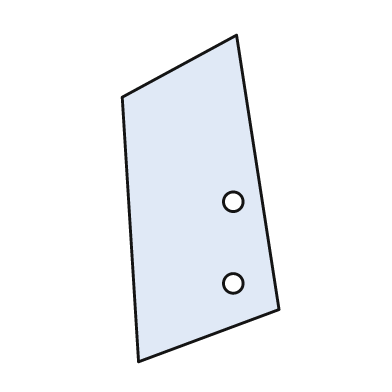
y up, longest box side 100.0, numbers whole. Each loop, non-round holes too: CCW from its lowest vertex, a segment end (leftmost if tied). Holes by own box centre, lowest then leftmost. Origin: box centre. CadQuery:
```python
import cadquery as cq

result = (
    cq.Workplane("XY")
    .moveTo(-19.0, -50.0)
    .lineTo(24.0, -34.0)
    .lineTo(11.0, 50.0)
    .lineTo(-24.0, 31.0)
    .close()
    .moveTo(10.0, -26.0)
    .circle(3.0)
    .moveTo(10.0, -1.0)
    .circle(3.0)
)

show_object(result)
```